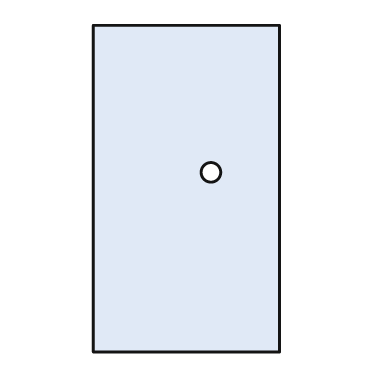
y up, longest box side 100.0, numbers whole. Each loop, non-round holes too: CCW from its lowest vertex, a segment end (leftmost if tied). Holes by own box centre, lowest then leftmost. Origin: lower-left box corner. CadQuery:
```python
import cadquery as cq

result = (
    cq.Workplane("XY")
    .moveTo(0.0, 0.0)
    .lineTo(57.0, 0.0)
    .lineTo(57.0, 100.0)
    .lineTo(0.0, 100.0)
    .close()
    .moveTo(36.0, 55.0)
    .circle(3.0)
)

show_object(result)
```